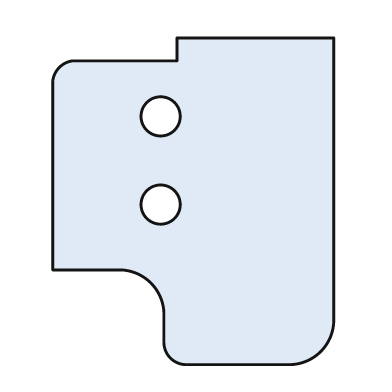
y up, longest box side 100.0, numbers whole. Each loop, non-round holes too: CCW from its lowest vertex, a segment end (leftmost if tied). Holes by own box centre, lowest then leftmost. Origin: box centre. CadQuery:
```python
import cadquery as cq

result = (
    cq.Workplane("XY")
    .moveTo(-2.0, -50.0)
    .lineTo(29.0, -50.0)
    .threePointArc((39.0, -46.0), (43.0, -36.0))
    .lineTo(43.0, 50.0)
    .lineTo(-5.0, 50.0)
    .lineTo(-5.0, 43.0)
    .lineTo(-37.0, 43.0)
    .threePointArc((-41.0, 41.0), (-43.0, 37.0))
    .lineTo(-43.0, -21.0)
    .lineTo(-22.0, -21.0)
    .threePointArc((-13.0, -25.0), (-9.0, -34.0))
    .lineTo(-9.0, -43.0)
    .threePointArc((-7.0, -48.0), (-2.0, -50.0))
    .close()
    .moveTo(-10.0, -1.0)
    .circle(6.0)
    .moveTo(-10.0, 26.0)
    .circle(6.0)
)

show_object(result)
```